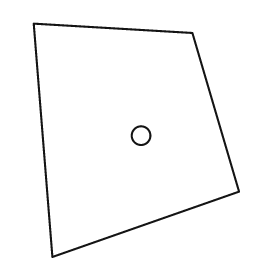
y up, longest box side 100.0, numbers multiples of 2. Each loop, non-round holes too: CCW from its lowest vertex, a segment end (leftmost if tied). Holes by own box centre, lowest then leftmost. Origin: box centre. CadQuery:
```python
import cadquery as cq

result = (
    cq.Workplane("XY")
    .moveTo(-36.0, -50.0)
    .lineTo(44.0, -22.0)
    .lineTo(24.0, 46.0)
    .lineTo(-44.0, 50.0)
    .close()
    .moveTo(2.0, 2.0)
    .circle(4.0)
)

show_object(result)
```